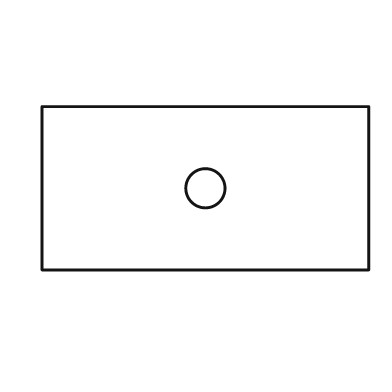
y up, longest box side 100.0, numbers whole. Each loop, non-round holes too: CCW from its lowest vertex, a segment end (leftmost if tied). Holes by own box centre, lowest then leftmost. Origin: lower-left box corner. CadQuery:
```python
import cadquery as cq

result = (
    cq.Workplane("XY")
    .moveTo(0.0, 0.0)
    .lineTo(100.0, 0.0)
    .lineTo(100.0, 50.0)
    .lineTo(0.0, 50.0)
    .close()
    .moveTo(50.0, 25.0)
    .circle(6.0)
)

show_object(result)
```